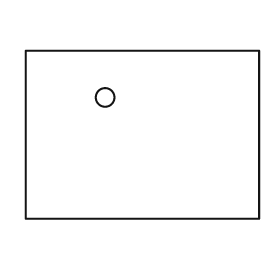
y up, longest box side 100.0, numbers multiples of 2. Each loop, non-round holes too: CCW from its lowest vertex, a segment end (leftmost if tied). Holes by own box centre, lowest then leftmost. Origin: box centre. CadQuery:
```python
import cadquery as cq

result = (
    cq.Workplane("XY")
    .moveTo(-50.0, -36.0)
    .lineTo(50.0, -36.0)
    .lineTo(50.0, 36.0)
    .lineTo(-50.0, 36.0)
    .close()
    .moveTo(-16.0, 16.0)
    .circle(4.0)
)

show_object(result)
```